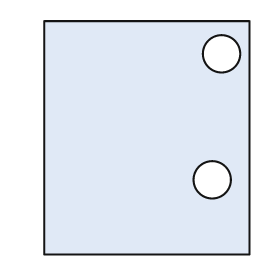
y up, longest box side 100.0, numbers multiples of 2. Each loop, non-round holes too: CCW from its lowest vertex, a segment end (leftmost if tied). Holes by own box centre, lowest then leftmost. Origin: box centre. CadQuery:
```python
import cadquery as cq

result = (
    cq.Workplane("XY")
    .moveTo(-44.0, -50.0)
    .lineTo(44.0, -50.0)
    .lineTo(44.0, 50.0)
    .lineTo(-44.0, 50.0)
    .close()
    .moveTo(28.0, -18.0)
    .circle(8.0)
    .moveTo(32.0, 36.0)
    .circle(8.0)
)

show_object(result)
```